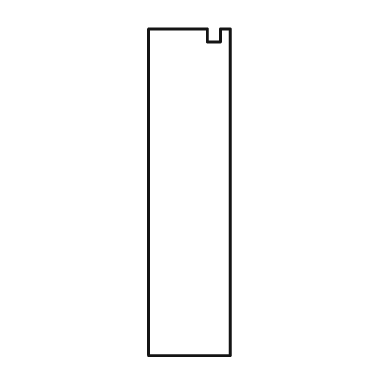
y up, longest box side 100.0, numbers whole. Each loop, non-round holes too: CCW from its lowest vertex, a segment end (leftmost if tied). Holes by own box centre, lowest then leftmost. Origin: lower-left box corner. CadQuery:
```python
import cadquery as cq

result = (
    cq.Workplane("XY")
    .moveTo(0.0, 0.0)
    .lineTo(25.0, 0.0)
    .lineTo(25.0, 100.0)
    .lineTo(22.0, 100.0)
    .lineTo(22.0, 96.0)
    .lineTo(18.0, 96.0)
    .lineTo(18.0, 100.0)
    .lineTo(0.0, 100.0)
    .close()
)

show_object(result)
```